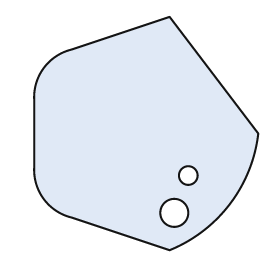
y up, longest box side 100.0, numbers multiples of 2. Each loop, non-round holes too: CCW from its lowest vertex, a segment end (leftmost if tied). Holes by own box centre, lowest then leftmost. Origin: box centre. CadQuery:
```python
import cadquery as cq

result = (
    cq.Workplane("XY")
    .moveTo(10.0, -50.0)
    .threePointArc((36.0, -30.0), (48.0, 0.0))
    .lineTo(10.0, 50.0)
    .lineTo(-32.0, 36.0)
    .threePointArc((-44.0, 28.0), (-48.0, 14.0))
    .lineTo(-48.0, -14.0)
    .threePointArc((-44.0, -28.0), (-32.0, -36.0))
    .close()
    .moveTo(12.0, -34.0)
    .circle(6.0)
    .moveTo(18.0, -18.0)
    .circle(4.0)
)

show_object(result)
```